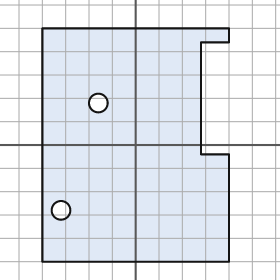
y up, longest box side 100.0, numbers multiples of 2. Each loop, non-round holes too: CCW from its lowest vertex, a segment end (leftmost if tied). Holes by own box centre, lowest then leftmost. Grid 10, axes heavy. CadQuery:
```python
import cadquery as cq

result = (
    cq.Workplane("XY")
    .moveTo(-40.0, -50.0)
    .lineTo(40.0, -50.0)
    .lineTo(40.0, -4.0)
    .lineTo(28.0, -4.0)
    .lineTo(28.0, 44.0)
    .lineTo(40.0, 44.0)
    .lineTo(40.0, 50.0)
    .lineTo(-40.0, 50.0)
    .close()
    .moveTo(-32.0, -28.0)
    .circle(4.0)
    .moveTo(-16.0, 18.0)
    .circle(4.0)
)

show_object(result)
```